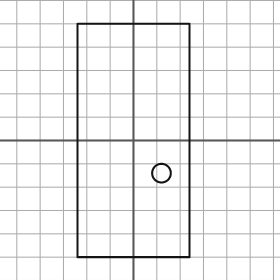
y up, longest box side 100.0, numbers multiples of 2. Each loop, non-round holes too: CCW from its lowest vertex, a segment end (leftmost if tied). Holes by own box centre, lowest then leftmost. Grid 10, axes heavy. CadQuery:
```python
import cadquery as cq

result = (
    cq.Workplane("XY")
    .moveTo(-24.0, -50.0)
    .lineTo(24.0, -50.0)
    .lineTo(24.0, 50.0)
    .lineTo(-24.0, 50.0)
    .close()
    .moveTo(12.0, -14.0)
    .circle(4.0)
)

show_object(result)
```